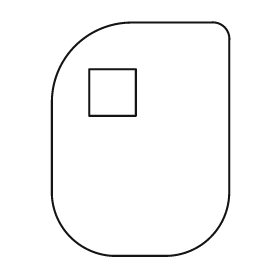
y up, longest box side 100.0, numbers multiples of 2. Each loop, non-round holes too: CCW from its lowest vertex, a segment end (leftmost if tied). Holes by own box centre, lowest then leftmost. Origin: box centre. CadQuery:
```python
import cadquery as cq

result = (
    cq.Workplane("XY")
    .moveTo(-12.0, -50.0)
    .lineTo(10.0, -50.0)
    .threePointArc((30.0, -42.0), (38.0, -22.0))
    .lineTo(38.0, 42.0)
    .threePointArc((36.0, 48.0), (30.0, 50.0))
    .lineTo(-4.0, 50.0)
    .threePointArc((-28.0, 40.0), (-38.0, 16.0))
    .lineTo(-38.0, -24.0)
    .threePointArc((-30.0, -42.0), (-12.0, -50.0))
    .close()
    .moveTo(-22.0, 10.0)
    .lineTo(-2.0, 10.0)
    .lineTo(-2.0, 30.0)
    .lineTo(-22.0, 30.0)
    .close()
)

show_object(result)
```